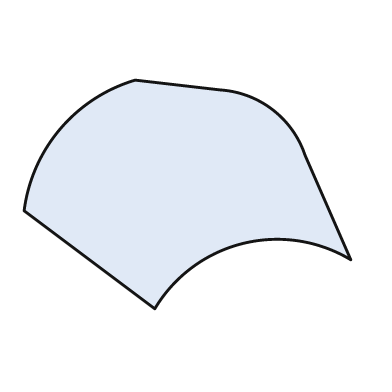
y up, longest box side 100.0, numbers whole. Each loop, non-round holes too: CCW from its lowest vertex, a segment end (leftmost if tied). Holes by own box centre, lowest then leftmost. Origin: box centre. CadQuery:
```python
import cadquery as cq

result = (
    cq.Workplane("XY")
    .moveTo(-10.0, -35.0)
    .threePointArc((17.0, -15.0), (50.0, -20.0))
    .lineTo(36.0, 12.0)
    .threePointArc((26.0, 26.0), (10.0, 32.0))
    .lineTo(-16.0, 35.0)
    .threePointArc((-39.0, 20.0), (-50.0, -5.0))
    .close()
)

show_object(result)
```